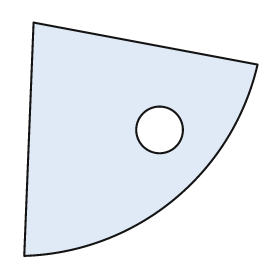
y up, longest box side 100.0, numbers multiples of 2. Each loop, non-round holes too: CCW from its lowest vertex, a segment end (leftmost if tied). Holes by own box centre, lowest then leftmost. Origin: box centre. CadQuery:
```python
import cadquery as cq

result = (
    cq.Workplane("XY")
    .moveTo(-50.0, -50.0)
    .threePointArc((14.0, -26.0), (50.0, 32.0))
    .lineTo(-46.0, 50.0)
    .close()
    .moveTo(8.0, 4.0)
    .circle(10.0)
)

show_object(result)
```